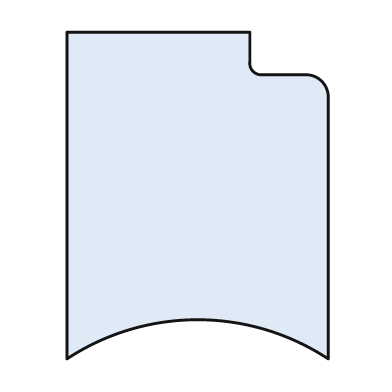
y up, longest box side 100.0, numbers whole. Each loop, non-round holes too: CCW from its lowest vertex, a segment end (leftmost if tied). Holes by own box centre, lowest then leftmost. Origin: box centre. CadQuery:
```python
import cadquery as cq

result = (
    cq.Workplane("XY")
    .moveTo(-40.0, -50.0)
    .threePointArc((0.0, -38.0), (40.0, -50.0))
    .lineTo(40.0, 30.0)
    .threePointArc((38.0, 35.0), (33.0, 37.0))
    .lineTo(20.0, 37.0)
    .threePointArc((17.0, 38.0), (16.0, 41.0))
    .lineTo(16.0, 50.0)
    .lineTo(-40.0, 50.0)
    .close()
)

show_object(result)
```